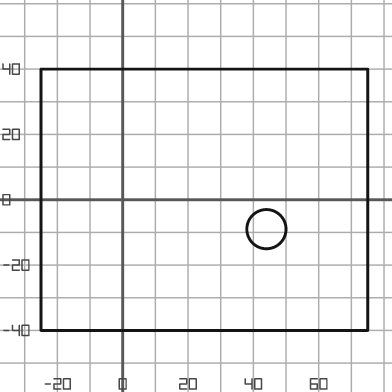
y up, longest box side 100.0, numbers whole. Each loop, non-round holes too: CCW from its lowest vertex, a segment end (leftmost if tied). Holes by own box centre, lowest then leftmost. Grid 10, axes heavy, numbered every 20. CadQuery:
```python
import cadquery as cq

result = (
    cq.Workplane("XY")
    .moveTo(-25.0, -40.0)
    .lineTo(75.0, -40.0)
    .lineTo(75.0, 40.0)
    .lineTo(-25.0, 40.0)
    .close()
    .moveTo(44.0, -9.0)
    .circle(6.0)
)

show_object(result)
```